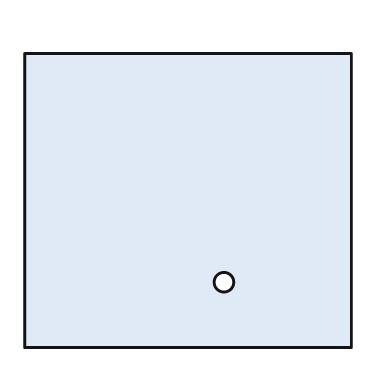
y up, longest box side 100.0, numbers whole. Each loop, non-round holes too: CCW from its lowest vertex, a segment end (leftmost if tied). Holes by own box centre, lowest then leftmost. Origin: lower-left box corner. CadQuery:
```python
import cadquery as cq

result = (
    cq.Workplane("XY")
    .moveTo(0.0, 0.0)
    .lineTo(100.0, 0.0)
    .lineTo(100.0, 90.0)
    .lineTo(0.0, 90.0)
    .close()
    .moveTo(61.0, 20.0)
    .circle(3.0)
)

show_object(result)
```